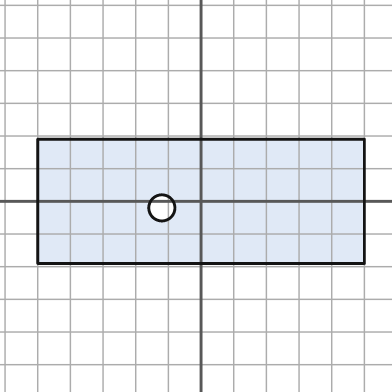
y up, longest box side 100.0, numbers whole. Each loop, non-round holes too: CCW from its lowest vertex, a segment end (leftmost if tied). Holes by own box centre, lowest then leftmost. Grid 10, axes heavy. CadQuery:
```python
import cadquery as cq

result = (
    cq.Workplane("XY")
    .moveTo(-50.0, -19.0)
    .lineTo(50.0, -19.0)
    .lineTo(50.0, 19.0)
    .lineTo(-50.0, 19.0)
    .close()
    .moveTo(-12.0, -2.0)
    .circle(4.0)
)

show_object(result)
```